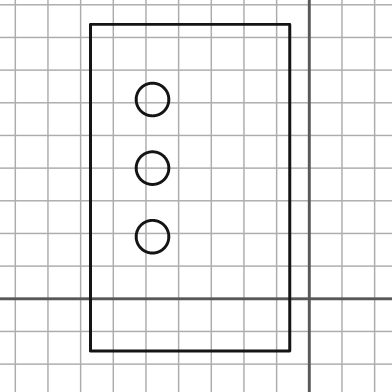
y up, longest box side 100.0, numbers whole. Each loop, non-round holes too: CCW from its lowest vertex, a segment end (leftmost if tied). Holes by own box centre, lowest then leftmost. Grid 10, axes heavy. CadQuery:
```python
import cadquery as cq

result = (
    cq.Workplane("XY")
    .moveTo(-67.0, -16.0)
    .lineTo(-6.0, -16.0)
    .lineTo(-6.0, 84.0)
    .lineTo(-67.0, 84.0)
    .close()
    .moveTo(-48.0, 19.0)
    .circle(5.0)
    .moveTo(-48.0, 40.0)
    .circle(5.0)
    .moveTo(-48.0, 61.0)
    .circle(5.0)
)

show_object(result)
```